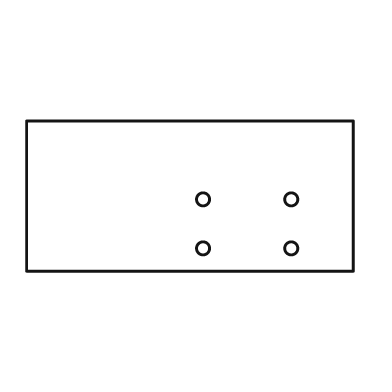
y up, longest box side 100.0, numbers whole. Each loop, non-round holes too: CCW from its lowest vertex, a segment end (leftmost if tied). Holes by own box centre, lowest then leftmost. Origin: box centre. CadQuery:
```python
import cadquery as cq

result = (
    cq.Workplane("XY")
    .moveTo(-50.0, -23.0)
    .lineTo(50.0, -23.0)
    .lineTo(50.0, 23.0)
    .lineTo(-50.0, 23.0)
    .close()
    .moveTo(4.0, -16.0)
    .circle(2.0)
    .moveTo(31.0, -16.0)
    .circle(2.0)
    .moveTo(4.0, -1.0)
    .circle(2.0)
    .moveTo(31.0, -1.0)
    .circle(2.0)
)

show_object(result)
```